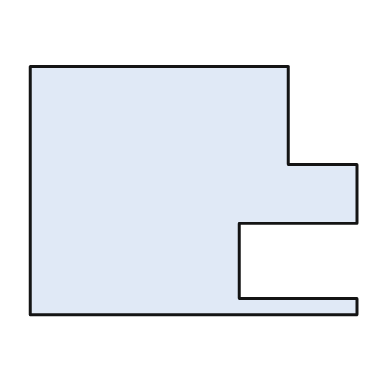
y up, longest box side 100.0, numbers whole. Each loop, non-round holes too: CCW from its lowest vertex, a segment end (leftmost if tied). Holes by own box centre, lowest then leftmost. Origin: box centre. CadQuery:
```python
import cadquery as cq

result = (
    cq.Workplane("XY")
    .moveTo(-50.0, -38.0)
    .lineTo(50.0, -38.0)
    .lineTo(50.0, -33.0)
    .lineTo(14.0, -33.0)
    .lineTo(14.0, -10.0)
    .lineTo(50.0, -10.0)
    .lineTo(50.0, 8.0)
    .lineTo(29.0, 8.0)
    .lineTo(29.0, 38.0)
    .lineTo(-50.0, 38.0)
    .close()
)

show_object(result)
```